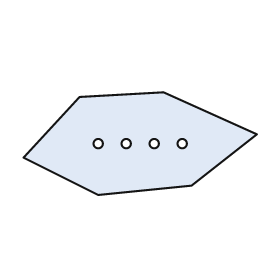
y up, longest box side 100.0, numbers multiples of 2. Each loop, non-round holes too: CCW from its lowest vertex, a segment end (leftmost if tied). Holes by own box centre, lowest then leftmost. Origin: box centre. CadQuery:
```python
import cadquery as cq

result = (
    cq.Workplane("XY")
    .moveTo(-18.0, -22.0)
    .lineTo(22.0, -18.0)
    .lineTo(50.0, 4.0)
    .lineTo(10.0, 22.0)
    .lineTo(-26.0, 20.0)
    .lineTo(-50.0, -6.0)
    .close()
    .moveTo(-18.0, 0.0)
    .circle(2.0)
    .moveTo(-6.0, 0.0)
    .circle(2.0)
    .moveTo(6.0, 0.0)
    .circle(2.0)
    .moveTo(18.0, 0.0)
    .circle(2.0)
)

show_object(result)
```